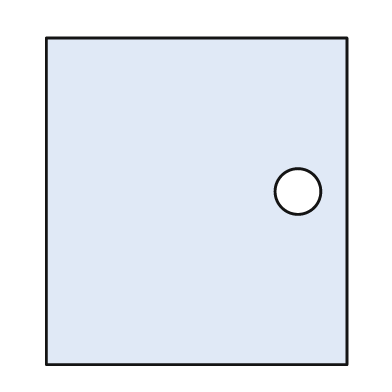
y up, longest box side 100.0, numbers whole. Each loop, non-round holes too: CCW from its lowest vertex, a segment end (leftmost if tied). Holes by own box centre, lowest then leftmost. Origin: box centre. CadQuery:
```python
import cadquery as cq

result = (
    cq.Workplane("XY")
    .moveTo(-46.0, -50.0)
    .lineTo(46.0, -50.0)
    .lineTo(46.0, 50.0)
    .lineTo(-46.0, 50.0)
    .close()
    .moveTo(31.0, 3.0)
    .circle(7.0)
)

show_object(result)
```